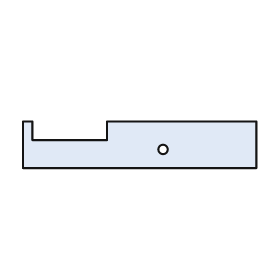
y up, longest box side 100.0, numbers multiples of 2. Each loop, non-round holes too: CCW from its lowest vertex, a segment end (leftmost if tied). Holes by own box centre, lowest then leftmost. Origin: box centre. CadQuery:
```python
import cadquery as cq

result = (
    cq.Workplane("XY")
    .moveTo(-50.0, -10.0)
    .lineTo(50.0, -10.0)
    .lineTo(50.0, 10.0)
    .lineTo(-14.0, 10.0)
    .lineTo(-14.0, 2.0)
    .lineTo(-46.0, 2.0)
    .lineTo(-46.0, 10.0)
    .lineTo(-50.0, 10.0)
    .close()
    .moveTo(10.0, -2.0)
    .circle(2.0)
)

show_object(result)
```